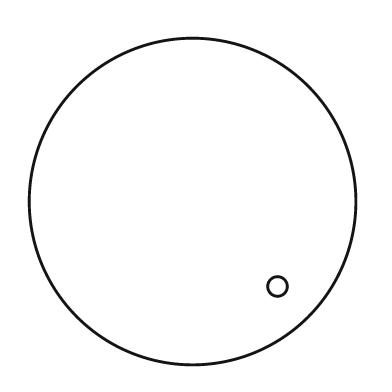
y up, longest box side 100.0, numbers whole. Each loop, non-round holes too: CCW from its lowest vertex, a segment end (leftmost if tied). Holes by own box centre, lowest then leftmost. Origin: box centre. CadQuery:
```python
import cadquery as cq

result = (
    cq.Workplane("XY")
    .moveTo(0.0, 0.0)
    .circle(50.0)
    .moveTo(26.0, -26.0)
    .circle(3.0)
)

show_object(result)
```